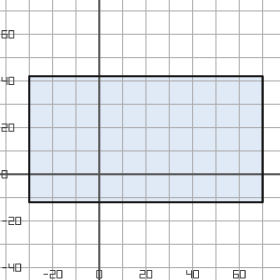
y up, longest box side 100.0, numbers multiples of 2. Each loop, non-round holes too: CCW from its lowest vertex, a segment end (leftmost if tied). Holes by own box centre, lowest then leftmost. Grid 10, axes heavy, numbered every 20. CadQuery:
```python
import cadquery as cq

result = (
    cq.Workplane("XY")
    .moveTo(-30.0, -12.0)
    .lineTo(70.0, -12.0)
    .lineTo(70.0, 42.0)
    .lineTo(-30.0, 42.0)
    .close()
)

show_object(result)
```